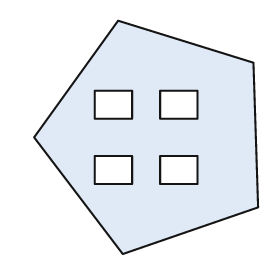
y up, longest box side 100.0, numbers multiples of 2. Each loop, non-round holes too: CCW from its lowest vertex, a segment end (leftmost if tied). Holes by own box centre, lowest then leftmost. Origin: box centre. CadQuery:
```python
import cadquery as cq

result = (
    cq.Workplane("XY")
    .moveTo(-10.0, -50.0)
    .lineTo(48.0, -30.0)
    .lineTo(46.0, 32.0)
    .lineTo(-12.0, 50.0)
    .lineTo(-48.0, 0.0)
    .close()
    .moveTo(-22.0, -20.0)
    .lineTo(-6.0, -20.0)
    .lineTo(-6.0, -8.0)
    .lineTo(-22.0, -8.0)
    .close()
    .moveTo(6.0, -20.0)
    .lineTo(22.0, -20.0)
    .lineTo(22.0, -8.0)
    .lineTo(6.0, -8.0)
    .close()
    .moveTo(-22.0, 8.0)
    .lineTo(-6.0, 8.0)
    .lineTo(-6.0, 20.0)
    .lineTo(-22.0, 20.0)
    .close()
    .moveTo(6.0, 8.0)
    .lineTo(22.0, 8.0)
    .lineTo(22.0, 20.0)
    .lineTo(6.0, 20.0)
    .close()
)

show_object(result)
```